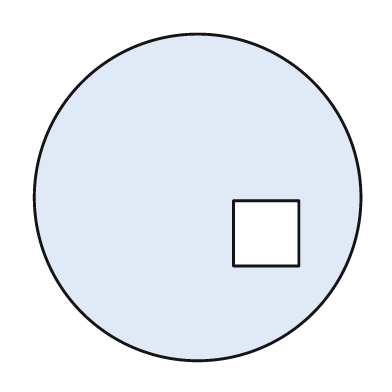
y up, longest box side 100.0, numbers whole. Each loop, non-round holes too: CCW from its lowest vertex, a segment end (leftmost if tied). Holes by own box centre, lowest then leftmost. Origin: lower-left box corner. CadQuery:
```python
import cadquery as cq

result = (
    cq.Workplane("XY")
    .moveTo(50.0, 50.0)
    .circle(50.0)
    .moveTo(61.0, 29.0)
    .lineTo(81.0, 29.0)
    .lineTo(81.0, 49.0)
    .lineTo(61.0, 49.0)
    .close()
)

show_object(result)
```